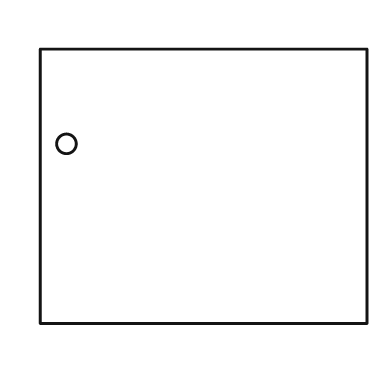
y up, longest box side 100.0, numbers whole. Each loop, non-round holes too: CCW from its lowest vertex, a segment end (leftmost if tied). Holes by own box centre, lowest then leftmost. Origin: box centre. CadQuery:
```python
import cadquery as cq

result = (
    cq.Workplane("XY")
    .moveTo(-50.0, -42.0)
    .lineTo(50.0, -42.0)
    .lineTo(50.0, 42.0)
    .lineTo(-50.0, 42.0)
    .close()
    .moveTo(-42.0, 13.0)
    .circle(3.0)
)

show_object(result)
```